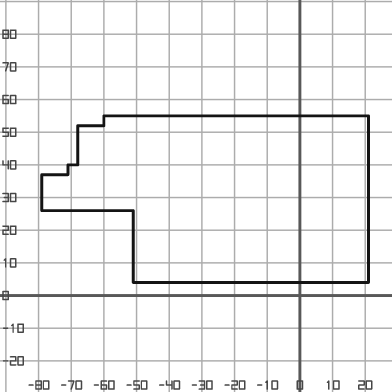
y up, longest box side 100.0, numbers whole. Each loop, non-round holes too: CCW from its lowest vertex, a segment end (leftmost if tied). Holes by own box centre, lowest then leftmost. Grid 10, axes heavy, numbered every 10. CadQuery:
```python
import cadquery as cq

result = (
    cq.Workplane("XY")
    .moveTo(-51.0, 4.0)
    .lineTo(21.0, 4.0)
    .lineTo(21.0, 55.0)
    .lineTo(-60.0, 55.0)
    .lineTo(-60.0, 52.0)
    .lineTo(-68.0, 52.0)
    .lineTo(-68.0, 40.0)
    .lineTo(-71.0, 40.0)
    .lineTo(-71.0, 37.0)
    .lineTo(-79.0, 37.0)
    .lineTo(-79.0, 26.0)
    .lineTo(-51.0, 26.0)
    .close()
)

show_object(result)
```